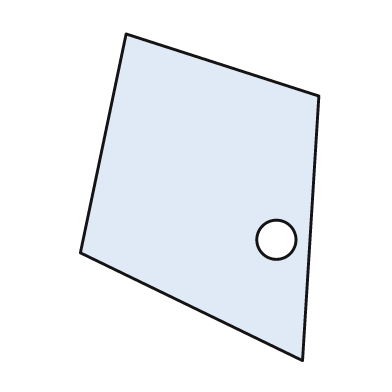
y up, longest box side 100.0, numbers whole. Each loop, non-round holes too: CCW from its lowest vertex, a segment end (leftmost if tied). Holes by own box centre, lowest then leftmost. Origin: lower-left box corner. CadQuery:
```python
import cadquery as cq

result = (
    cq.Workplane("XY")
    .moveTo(68.0, 0.0)
    .lineTo(73.0, 81.0)
    .lineTo(14.0, 100.0)
    .lineTo(0.0, 33.0)
    .close()
    .moveTo(60.0, 37.0)
    .circle(6.0)
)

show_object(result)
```